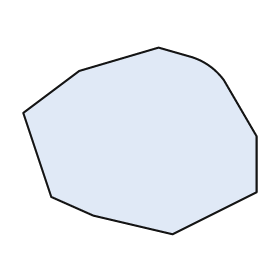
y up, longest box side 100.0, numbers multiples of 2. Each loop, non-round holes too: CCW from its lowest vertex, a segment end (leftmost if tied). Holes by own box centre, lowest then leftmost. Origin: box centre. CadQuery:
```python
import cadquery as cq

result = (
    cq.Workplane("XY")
    .moveTo(14.0, -40.0)
    .lineTo(50.0, -22.0)
    .lineTo(50.0, 2.0)
    .lineTo(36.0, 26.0)
    .threePointArc((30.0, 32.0), (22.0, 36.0))
    .lineTo(8.0, 40.0)
    .lineTo(-26.0, 30.0)
    .lineTo(-50.0, 12.0)
    .lineTo(-38.0, -24.0)
    .lineTo(-20.0, -32.0)
    .close()
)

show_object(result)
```